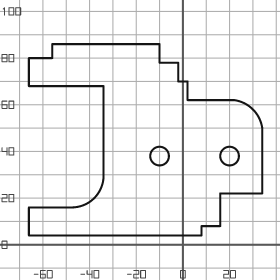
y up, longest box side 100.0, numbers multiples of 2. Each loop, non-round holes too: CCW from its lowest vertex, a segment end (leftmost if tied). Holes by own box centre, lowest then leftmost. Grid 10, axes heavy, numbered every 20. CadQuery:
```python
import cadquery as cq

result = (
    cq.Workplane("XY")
    .moveTo(-66.0, 4.0)
    .lineTo(8.0, 4.0)
    .lineTo(8.0, 8.0)
    .lineTo(16.0, 8.0)
    .lineTo(16.0, 22.0)
    .lineTo(34.0, 22.0)
    .lineTo(34.0, 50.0)
    .threePointArc((30.0, 58.0), (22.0, 62.0))
    .lineTo(2.0, 62.0)
    .lineTo(2.0, 70.0)
    .lineTo(-2.0, 70.0)
    .lineTo(-2.0, 78.0)
    .lineTo(-10.0, 78.0)
    .lineTo(-10.0, 86.0)
    .lineTo(-56.0, 86.0)
    .lineTo(-56.0, 80.0)
    .lineTo(-66.0, 80.0)
    .lineTo(-66.0, 68.0)
    .lineTo(-34.0, 68.0)
    .lineTo(-34.0, 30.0)
    .threePointArc((-38.0, 20.0), (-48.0, 16.0))
    .lineTo(-66.0, 16.0)
    .close()
    .moveTo(-10.0, 38.0)
    .circle(4.0)
    .moveTo(20.0, 38.0)
    .circle(4.0)
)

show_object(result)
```